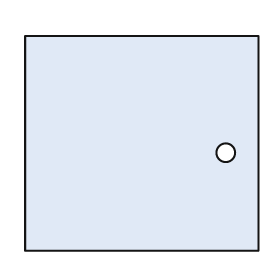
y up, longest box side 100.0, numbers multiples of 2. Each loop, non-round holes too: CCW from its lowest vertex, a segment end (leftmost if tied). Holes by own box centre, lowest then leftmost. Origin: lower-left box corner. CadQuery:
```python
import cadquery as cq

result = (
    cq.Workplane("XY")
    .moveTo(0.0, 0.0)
    .lineTo(100.0, 0.0)
    .lineTo(100.0, 92.0)
    .lineTo(0.0, 92.0)
    .close()
    .moveTo(86.0, 42.0)
    .circle(4.0)
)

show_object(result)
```